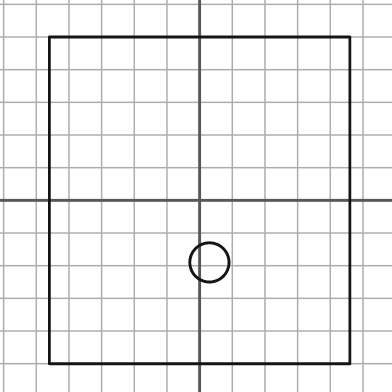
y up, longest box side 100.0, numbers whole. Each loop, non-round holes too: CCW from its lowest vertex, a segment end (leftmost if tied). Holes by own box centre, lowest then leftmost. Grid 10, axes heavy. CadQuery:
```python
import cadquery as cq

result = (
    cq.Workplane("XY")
    .moveTo(-46.0, -50.0)
    .lineTo(46.0, -50.0)
    .lineTo(46.0, 50.0)
    .lineTo(-46.0, 50.0)
    .close()
    .moveTo(3.0, -19.0)
    .circle(6.0)
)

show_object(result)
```